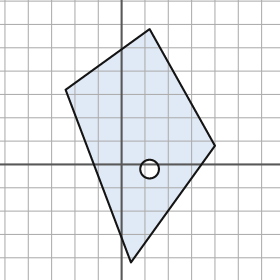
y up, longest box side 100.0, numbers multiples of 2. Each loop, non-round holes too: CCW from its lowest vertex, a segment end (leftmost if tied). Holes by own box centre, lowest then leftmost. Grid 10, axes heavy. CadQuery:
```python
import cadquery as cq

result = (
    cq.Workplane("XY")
    .moveTo(4.0, -42.0)
    .lineTo(40.0, 8.0)
    .lineTo(12.0, 58.0)
    .lineTo(-24.0, 32.0)
    .close()
    .moveTo(12.0, -2.0)
    .circle(4.0)
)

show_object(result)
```